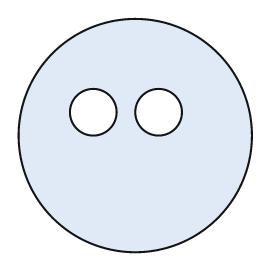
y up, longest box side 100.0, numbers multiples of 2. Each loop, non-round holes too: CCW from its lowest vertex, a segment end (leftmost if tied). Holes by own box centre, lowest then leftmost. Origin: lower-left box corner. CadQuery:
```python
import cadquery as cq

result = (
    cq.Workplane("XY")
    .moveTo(50.0, 50.0)
    .circle(50.0)
    .moveTo(32.0, 60.0)
    .circle(10.0)
    .moveTo(60.0, 60.0)
    .circle(10.0)
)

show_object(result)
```